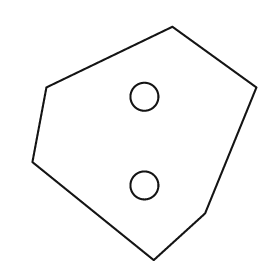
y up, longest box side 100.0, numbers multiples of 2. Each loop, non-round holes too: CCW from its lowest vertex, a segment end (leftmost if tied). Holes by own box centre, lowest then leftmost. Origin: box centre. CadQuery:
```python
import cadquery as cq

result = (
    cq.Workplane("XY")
    .moveTo(4.0, -50.0)
    .lineTo(26.0, -30.0)
    .lineTo(48.0, 24.0)
    .lineTo(12.0, 50.0)
    .lineTo(-42.0, 24.0)
    .lineTo(-48.0, -8.0)
    .close()
    .moveTo(0.0, -18.0)
    .circle(6.0)
    .moveTo(0.0, 20.0)
    .circle(6.0)
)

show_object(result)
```